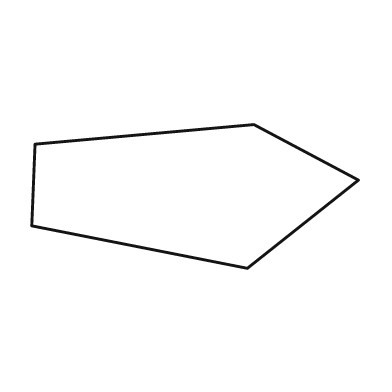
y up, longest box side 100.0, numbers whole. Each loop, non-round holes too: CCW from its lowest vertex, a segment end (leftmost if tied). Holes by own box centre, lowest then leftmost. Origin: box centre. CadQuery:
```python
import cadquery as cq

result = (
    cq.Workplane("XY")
    .moveTo(16.0, -22.0)
    .lineTo(50.0, 5.0)
    .lineTo(18.0, 22.0)
    .lineTo(-49.0, 16.0)
    .lineTo(-50.0, -9.0)
    .close()
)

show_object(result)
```